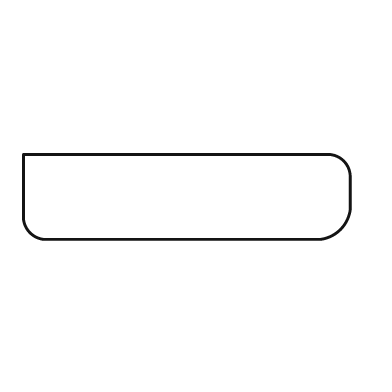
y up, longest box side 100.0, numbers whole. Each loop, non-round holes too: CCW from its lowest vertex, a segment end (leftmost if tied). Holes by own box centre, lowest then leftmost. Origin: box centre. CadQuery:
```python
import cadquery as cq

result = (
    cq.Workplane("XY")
    .moveTo(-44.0, -13.0)
    .lineTo(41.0, -13.0)
    .threePointArc((47.0, -10.0), (50.0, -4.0))
    .lineTo(50.0, 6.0)
    .threePointArc((48.0, 11.0), (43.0, 13.0))
    .lineTo(-50.0, 13.0)
    .lineTo(-50.0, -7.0)
    .threePointArc((-48.0, -11.0), (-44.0, -13.0))
    .close()
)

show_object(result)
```